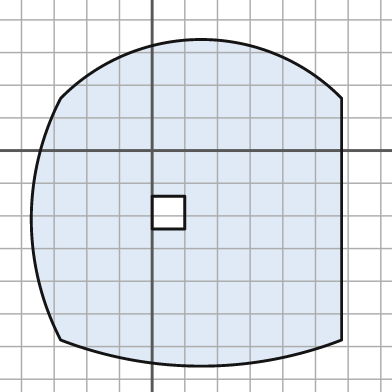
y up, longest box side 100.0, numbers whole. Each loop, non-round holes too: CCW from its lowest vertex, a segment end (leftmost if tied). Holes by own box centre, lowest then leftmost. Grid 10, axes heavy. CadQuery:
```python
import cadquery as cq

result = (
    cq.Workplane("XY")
    .moveTo(-28.0, -58.0)
    .threePointArc((15.0, -66.0), (58.0, -58.0))
    .lineTo(58.0, 16.0)
    .threePointArc((15.0, 34.0), (-28.0, 16.0))
    .threePointArc((-37.0, -21.0), (-28.0, -58.0))
    .close()
    .moveTo(0.0, -24.0)
    .lineTo(10.0, -24.0)
    .lineTo(10.0, -14.0)
    .lineTo(0.0, -14.0)
    .close()
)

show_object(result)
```